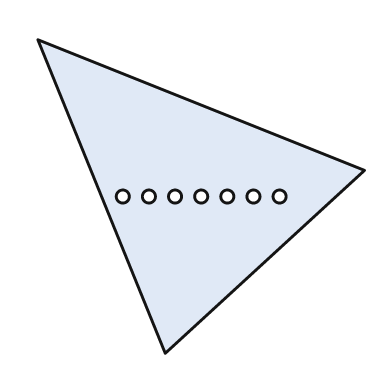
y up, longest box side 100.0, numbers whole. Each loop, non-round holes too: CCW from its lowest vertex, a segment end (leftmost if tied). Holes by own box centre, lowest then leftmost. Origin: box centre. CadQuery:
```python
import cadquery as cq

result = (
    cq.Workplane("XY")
    .moveTo(-11.0, -48.0)
    .lineTo(50.0, 8.0)
    .lineTo(-50.0, 48.0)
    .close()
    .moveTo(-24.0, 0.0)
    .circle(2.0)
    .moveTo(-16.0, 0.0)
    .circle(2.0)
    .moveTo(-8.0, 0.0)
    .circle(2.0)
    .moveTo(0.0, 0.0)
    .circle(2.0)
    .moveTo(8.0, 0.0)
    .circle(2.0)
    .moveTo(16.0, 0.0)
    .circle(2.0)
    .moveTo(24.0, 0.0)
    .circle(2.0)
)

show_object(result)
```